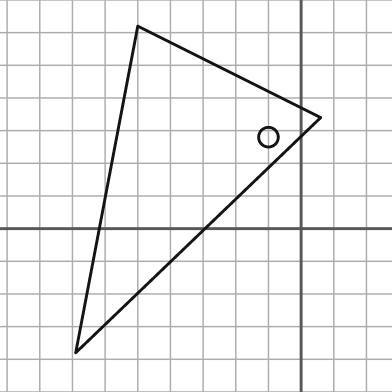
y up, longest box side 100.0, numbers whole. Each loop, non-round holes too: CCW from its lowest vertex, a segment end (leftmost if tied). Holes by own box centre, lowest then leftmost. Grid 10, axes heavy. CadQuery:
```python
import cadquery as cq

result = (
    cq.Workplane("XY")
    .moveTo(-69.0, -38.0)
    .lineTo(6.0, 34.0)
    .lineTo(-50.0, 62.0)
    .close()
    .moveTo(-10.0, 28.0)
    .circle(3.0)
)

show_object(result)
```